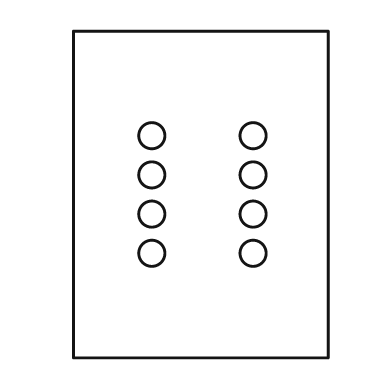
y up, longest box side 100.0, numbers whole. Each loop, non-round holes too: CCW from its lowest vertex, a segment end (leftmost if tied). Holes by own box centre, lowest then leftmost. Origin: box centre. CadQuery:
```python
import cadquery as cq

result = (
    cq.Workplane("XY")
    .moveTo(-39.0, -50.0)
    .lineTo(39.0, -50.0)
    .lineTo(39.0, 50.0)
    .lineTo(-39.0, 50.0)
    .close()
    .moveTo(-15.0, -18.0)
    .circle(4.0)
    .moveTo(16.0, -18.0)
    .circle(4.0)
    .moveTo(-15.0, -6.0)
    .circle(4.0)
    .moveTo(16.0, -6.0)
    .circle(4.0)
    .moveTo(-15.0, 6.0)
    .circle(4.0)
    .moveTo(16.0, 6.0)
    .circle(4.0)
    .moveTo(-15.0, 18.0)
    .circle(4.0)
    .moveTo(16.0, 18.0)
    .circle(4.0)
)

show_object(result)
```